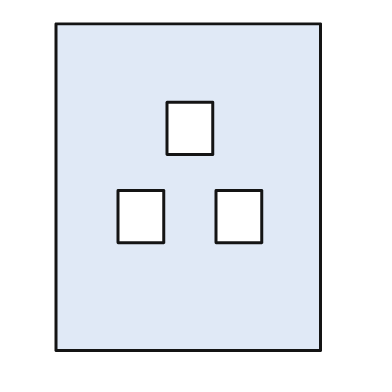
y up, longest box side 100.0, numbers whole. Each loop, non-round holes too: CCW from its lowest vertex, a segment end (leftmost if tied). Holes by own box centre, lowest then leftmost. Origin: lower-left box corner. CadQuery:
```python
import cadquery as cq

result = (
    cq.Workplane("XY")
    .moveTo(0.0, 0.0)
    .lineTo(81.0, 0.0)
    .lineTo(81.0, 100.0)
    .lineTo(0.0, 100.0)
    .close()
    .moveTo(19.0, 33.0)
    .lineTo(33.0, 33.0)
    .lineTo(33.0, 49.0)
    .lineTo(19.0, 49.0)
    .close()
    .moveTo(49.0, 33.0)
    .lineTo(63.0, 33.0)
    .lineTo(63.0, 49.0)
    .lineTo(49.0, 49.0)
    .close()
    .moveTo(34.0, 60.0)
    .lineTo(48.0, 60.0)
    .lineTo(48.0, 76.0)
    .lineTo(34.0, 76.0)
    .close()
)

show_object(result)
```